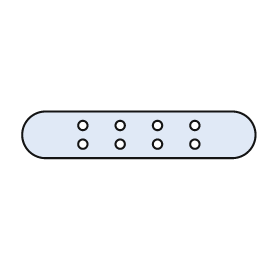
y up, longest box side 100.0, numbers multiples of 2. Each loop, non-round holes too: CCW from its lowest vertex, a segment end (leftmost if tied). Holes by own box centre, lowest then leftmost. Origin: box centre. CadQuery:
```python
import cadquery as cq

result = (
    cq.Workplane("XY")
    .moveTo(-40.0, -10.0)
    .lineTo(40.0, -10.0)
    .threePointArc((50.0, 0.0), (40.0, 10.0))
    .lineTo(-40.0, 10.0)
    .threePointArc((-50.0, 0.0), (-40.0, -10.0))
    .close()
    .moveTo(-24.0, -4.0)
    .circle(2.0)
    .moveTo(-8.0, -4.0)
    .circle(2.0)
    .moveTo(8.0, -4.0)
    .circle(2.0)
    .moveTo(24.0, -4.0)
    .circle(2.0)
    .moveTo(-24.0, 4.0)
    .circle(2.0)
    .moveTo(-8.0, 4.0)
    .circle(2.0)
    .moveTo(8.0, 4.0)
    .circle(2.0)
    .moveTo(24.0, 4.0)
    .circle(2.0)
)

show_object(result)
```